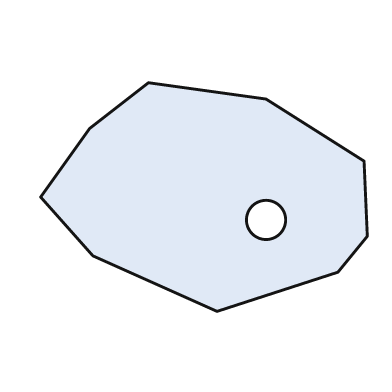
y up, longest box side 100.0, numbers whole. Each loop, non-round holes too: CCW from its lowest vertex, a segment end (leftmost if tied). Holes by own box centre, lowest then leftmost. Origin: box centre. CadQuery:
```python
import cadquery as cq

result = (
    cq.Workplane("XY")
    .moveTo(4.0, -35.0)
    .lineTo(41.0, -23.0)
    .lineTo(50.0, -12.0)
    .lineTo(49.0, 11.0)
    .lineTo(19.0, 30.0)
    .lineTo(-17.0, 35.0)
    .lineTo(-35.0, 21.0)
    .lineTo(-50.0, 0.0)
    .lineTo(-34.0, -18.0)
    .close()
    .moveTo(19.0, -7.0)
    .circle(6.0)
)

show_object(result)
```